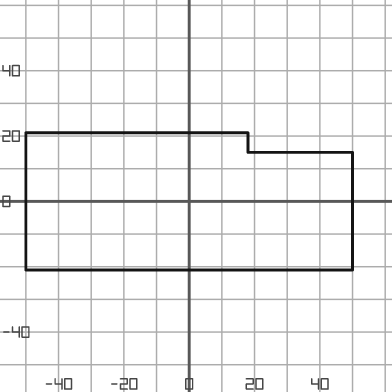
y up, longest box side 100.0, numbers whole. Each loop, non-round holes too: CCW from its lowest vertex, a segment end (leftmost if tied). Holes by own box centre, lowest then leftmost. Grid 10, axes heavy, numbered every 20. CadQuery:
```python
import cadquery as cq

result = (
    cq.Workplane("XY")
    .moveTo(-50.0, -21.0)
    .lineTo(50.0, -21.0)
    .lineTo(50.0, 15.0)
    .lineTo(18.0, 15.0)
    .lineTo(18.0, 21.0)
    .lineTo(-50.0, 21.0)
    .close()
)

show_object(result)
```